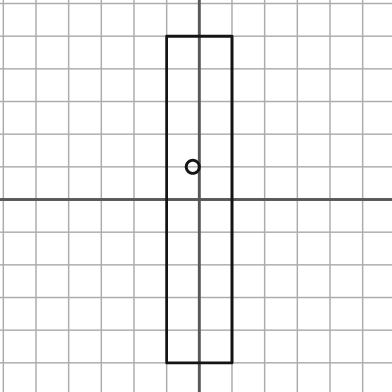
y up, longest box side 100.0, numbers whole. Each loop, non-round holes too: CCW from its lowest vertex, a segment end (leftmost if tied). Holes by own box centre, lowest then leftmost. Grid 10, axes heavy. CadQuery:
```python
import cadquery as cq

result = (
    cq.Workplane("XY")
    .moveTo(-10.0, -50.0)
    .lineTo(10.0, -50.0)
    .lineTo(10.0, 50.0)
    .lineTo(-10.0, 50.0)
    .close()
    .moveTo(-2.0, 10.0)
    .circle(2.0)
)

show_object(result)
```